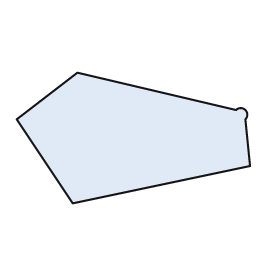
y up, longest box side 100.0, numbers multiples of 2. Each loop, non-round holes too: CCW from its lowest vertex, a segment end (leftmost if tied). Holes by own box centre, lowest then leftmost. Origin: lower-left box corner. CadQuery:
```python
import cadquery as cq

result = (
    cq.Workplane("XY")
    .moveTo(24.0, 0.0)
    .lineTo(100.0, 16.0)
    .lineTo(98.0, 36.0)
    .threePointArc((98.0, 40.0), (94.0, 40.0))
    .lineTo(26.0, 56.0)
    .lineTo(0.0, 36.0)
    .close()
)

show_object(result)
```